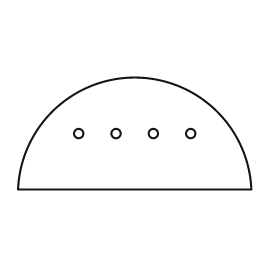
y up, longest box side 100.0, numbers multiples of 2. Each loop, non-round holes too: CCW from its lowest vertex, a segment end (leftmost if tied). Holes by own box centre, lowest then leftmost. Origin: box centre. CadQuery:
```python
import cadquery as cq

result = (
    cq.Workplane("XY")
    .moveTo(-50.0, -24.0)
    .lineTo(50.0, -24.0)
    .threePointArc((0.0, 24.0), (-50.0, -24.0))
    .close()
    .moveTo(-24.0, 0.0)
    .circle(2.0)
    .moveTo(-8.0, 0.0)
    .circle(2.0)
    .moveTo(8.0, 0.0)
    .circle(2.0)
    .moveTo(24.0, 0.0)
    .circle(2.0)
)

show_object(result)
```